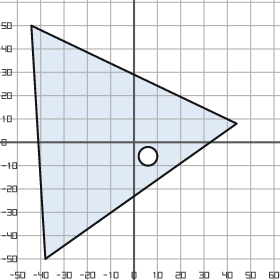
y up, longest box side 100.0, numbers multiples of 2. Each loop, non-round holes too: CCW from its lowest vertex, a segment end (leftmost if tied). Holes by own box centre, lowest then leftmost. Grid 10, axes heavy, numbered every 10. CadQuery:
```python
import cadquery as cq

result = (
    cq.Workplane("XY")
    .moveTo(-38.0, -50.0)
    .lineTo(44.0, 8.0)
    .lineTo(-44.0, 50.0)
    .close()
    .moveTo(6.0, -6.0)
    .circle(4.0)
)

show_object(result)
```